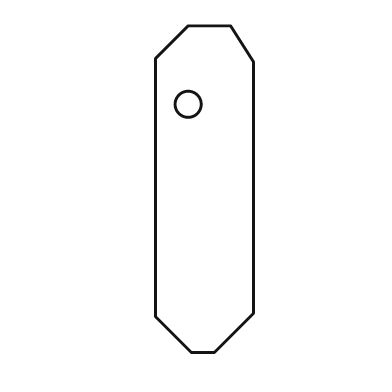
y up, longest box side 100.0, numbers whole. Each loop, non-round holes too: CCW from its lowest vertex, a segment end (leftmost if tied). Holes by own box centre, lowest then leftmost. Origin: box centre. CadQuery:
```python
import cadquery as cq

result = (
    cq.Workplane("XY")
    .moveTo(-4.0, -50.0)
    .lineTo(3.0, -50.0)
    .lineTo(15.0, -38.0)
    .lineTo(15.0, 39.0)
    .lineTo(8.0, 50.0)
    .lineTo(-5.0, 50.0)
    .lineTo(-15.0, 40.0)
    .lineTo(-15.0, -39.0)
    .close()
    .moveTo(-5.0, 26.0)
    .circle(4.0)
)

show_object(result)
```